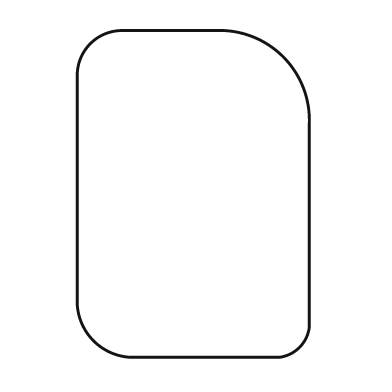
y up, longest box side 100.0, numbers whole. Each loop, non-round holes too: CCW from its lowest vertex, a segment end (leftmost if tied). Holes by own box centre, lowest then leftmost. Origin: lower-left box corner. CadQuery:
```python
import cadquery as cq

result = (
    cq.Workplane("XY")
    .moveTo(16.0, 0.0)
    .lineTo(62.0, 0.0)
    .threePointArc((68.0, 3.0), (71.0, 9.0))
    .lineTo(71.0, 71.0)
    .threePointArc((63.0, 92.0), (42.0, 100.0))
    .lineTo(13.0, 100.0)
    .threePointArc((4.0, 96.0), (0.0, 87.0))
    .lineTo(0.0, 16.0)
    .threePointArc((5.0, 5.0), (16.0, 0.0))
    .close()
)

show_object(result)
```